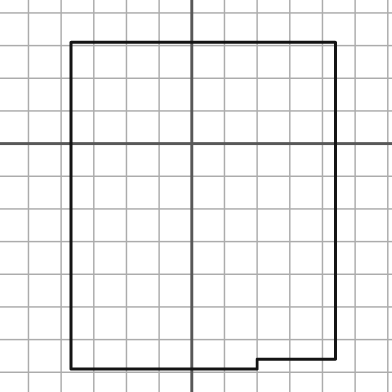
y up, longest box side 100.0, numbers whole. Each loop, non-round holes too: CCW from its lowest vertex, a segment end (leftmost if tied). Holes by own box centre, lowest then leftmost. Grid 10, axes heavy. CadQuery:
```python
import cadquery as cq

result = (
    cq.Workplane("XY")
    .moveTo(-37.0, -69.0)
    .lineTo(20.0, -69.0)
    .lineTo(20.0, -66.0)
    .lineTo(44.0, -66.0)
    .lineTo(44.0, 31.0)
    .lineTo(-37.0, 31.0)
    .close()
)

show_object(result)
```